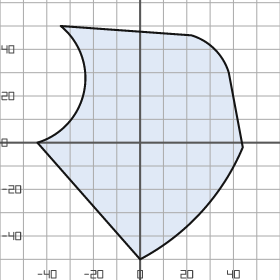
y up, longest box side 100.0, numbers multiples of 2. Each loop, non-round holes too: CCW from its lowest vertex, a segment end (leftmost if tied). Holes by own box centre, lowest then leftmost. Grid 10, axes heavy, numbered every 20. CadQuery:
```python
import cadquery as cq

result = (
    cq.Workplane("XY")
    .moveTo(0.0, -50.0)
    .threePointArc((26.0, -30.0), (44.0, -2.0))
    .lineTo(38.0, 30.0)
    .threePointArc((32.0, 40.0), (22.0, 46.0))
    .lineTo(-34.0, 50.0)
    .threePointArc((-24.0, 22.0), (-44.0, 0.0))
    .close()
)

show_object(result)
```